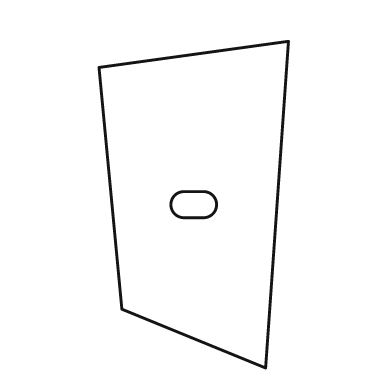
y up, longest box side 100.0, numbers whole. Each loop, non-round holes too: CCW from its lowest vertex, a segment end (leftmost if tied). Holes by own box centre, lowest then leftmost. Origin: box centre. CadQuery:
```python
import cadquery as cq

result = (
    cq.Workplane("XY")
    .moveTo(22.0, -50.0)
    .lineTo(29.0, 50.0)
    .lineTo(-29.0, 42.0)
    .lineTo(-22.0, -32.0)
    .close()
    .moveTo(-3.0, -4.0)
    .lineTo(3.0, -4.0)
    .threePointArc((7.0, 0.0), (3.0, 4.0))
    .lineTo(-3.0, 4.0)
    .threePointArc((-7.0, 0.0), (-3.0, -4.0))
    .close()
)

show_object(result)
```